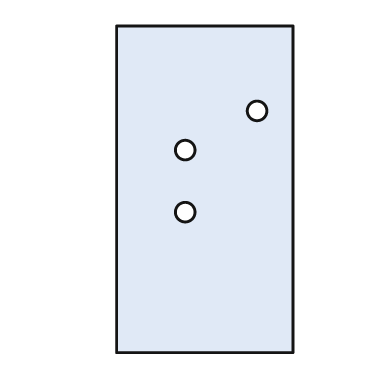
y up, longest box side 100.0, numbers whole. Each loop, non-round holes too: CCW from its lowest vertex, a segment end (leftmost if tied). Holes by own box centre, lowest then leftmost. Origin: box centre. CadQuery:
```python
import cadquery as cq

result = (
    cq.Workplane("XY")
    .moveTo(-27.0, -50.0)
    .lineTo(27.0, -50.0)
    .lineTo(27.0, 50.0)
    .lineTo(-27.0, 50.0)
    .close()
    .moveTo(-6.0, -7.0)
    .circle(3.0)
    .moveTo(-6.0, 12.0)
    .circle(3.0)
    .moveTo(16.0, 24.0)
    .circle(3.0)
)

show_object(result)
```